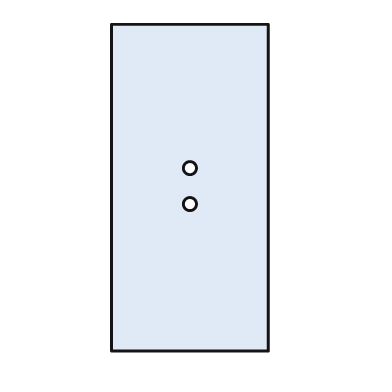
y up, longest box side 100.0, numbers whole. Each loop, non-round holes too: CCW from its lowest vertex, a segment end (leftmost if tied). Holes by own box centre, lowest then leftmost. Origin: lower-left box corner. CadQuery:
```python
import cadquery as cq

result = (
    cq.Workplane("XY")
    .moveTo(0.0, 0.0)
    .lineTo(48.0, 0.0)
    .lineTo(48.0, 100.0)
    .lineTo(0.0, 100.0)
    .close()
    .moveTo(24.0, 45.0)
    .circle(2.0)
    .moveTo(24.0, 56.0)
    .circle(2.0)
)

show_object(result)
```